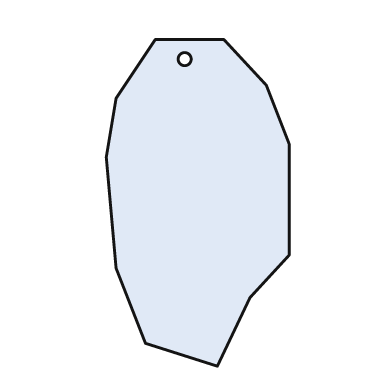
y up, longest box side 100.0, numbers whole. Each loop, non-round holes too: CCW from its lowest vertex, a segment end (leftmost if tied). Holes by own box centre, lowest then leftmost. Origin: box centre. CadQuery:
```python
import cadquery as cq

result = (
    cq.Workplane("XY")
    .moveTo(6.0, -50.0)
    .lineTo(16.0, -29.0)
    .lineTo(28.0, -16.0)
    .lineTo(28.0, 18.0)
    .lineTo(21.0, 36.0)
    .lineTo(8.0, 50.0)
    .lineTo(-13.0, 50.0)
    .lineTo(-25.0, 32.0)
    .lineTo(-28.0, 14.0)
    .lineTo(-25.0, -20.0)
    .lineTo(-16.0, -43.0)
    .close()
    .moveTo(-4.0, 44.0)
    .circle(2.0)
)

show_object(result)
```